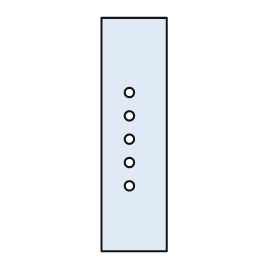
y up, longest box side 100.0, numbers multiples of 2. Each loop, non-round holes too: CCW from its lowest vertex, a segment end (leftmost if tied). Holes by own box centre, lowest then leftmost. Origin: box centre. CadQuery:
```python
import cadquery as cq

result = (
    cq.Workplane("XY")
    .moveTo(-14.0, -50.0)
    .lineTo(14.0, -50.0)
    .lineTo(14.0, 50.0)
    .lineTo(-14.0, 50.0)
    .close()
    .moveTo(-2.0, -22.0)
    .circle(2.0)
    .moveTo(-2.0, -12.0)
    .circle(2.0)
    .moveTo(-2.0, -2.0)
    .circle(2.0)
    .moveTo(-2.0, 8.0)
    .circle(2.0)
    .moveTo(-2.0, 18.0)
    .circle(2.0)
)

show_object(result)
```